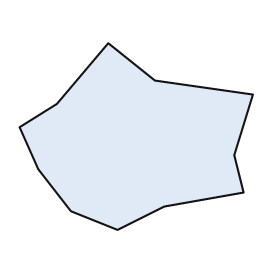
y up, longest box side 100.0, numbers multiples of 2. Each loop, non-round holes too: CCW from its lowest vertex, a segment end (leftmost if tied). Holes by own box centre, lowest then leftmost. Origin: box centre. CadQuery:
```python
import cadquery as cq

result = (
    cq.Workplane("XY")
    .moveTo(-8.0, -40.0)
    .lineTo(12.0, -30.0)
    .lineTo(46.0, -24.0)
    .lineTo(42.0, -8.0)
    .lineTo(50.0, 18.0)
    .lineTo(8.0, 24.0)
    .lineTo(-12.0, 40.0)
    .lineTo(-34.0, 14.0)
    .lineTo(-50.0, 4.0)
    .lineTo(-42.0, -14.0)
    .lineTo(-28.0, -32.0)
    .close()
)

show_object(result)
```